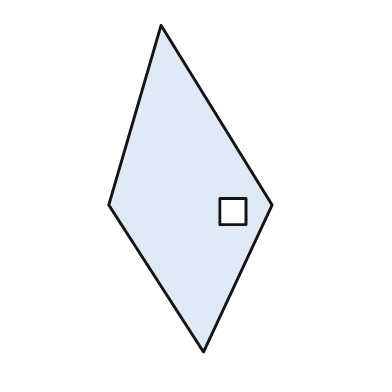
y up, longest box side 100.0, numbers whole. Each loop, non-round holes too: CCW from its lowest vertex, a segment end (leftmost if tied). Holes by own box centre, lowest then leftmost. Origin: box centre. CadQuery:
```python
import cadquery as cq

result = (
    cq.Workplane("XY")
    .moveTo(4.0, -50.0)
    .lineTo(25.0, -5.0)
    .lineTo(-9.0, 50.0)
    .lineTo(-25.0, -5.0)
    .close()
    .moveTo(9.0, -11.0)
    .lineTo(17.0, -11.0)
    .lineTo(17.0, -3.0)
    .lineTo(9.0, -3.0)
    .close()
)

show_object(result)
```